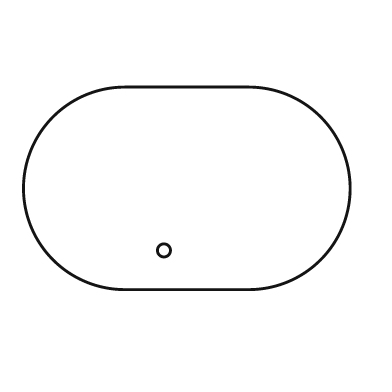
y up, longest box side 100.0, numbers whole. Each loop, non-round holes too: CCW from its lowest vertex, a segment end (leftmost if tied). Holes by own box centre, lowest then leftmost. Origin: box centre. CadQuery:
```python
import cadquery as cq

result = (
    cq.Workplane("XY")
    .moveTo(-19.0, -31.0)
    .lineTo(19.0, -31.0)
    .threePointArc((50.0, 0.0), (19.0, 31.0))
    .lineTo(-19.0, 31.0)
    .threePointArc((-50.0, 0.0), (-19.0, -31.0))
    .close()
    .moveTo(-7.0, -19.0)
    .circle(2.0)
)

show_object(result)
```